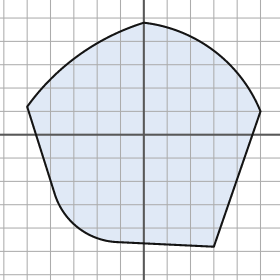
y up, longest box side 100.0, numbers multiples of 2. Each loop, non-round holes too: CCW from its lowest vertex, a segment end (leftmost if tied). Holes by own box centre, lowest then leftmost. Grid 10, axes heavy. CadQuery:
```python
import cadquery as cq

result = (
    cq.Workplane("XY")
    .moveTo(30.0, -48.0)
    .lineTo(50.0, 10.0)
    .threePointArc((30.0, 36.0), (0.0, 48.0))
    .threePointArc((-28.0, 34.0), (-50.0, 12.0))
    .lineTo(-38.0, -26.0)
    .threePointArc((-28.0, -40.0), (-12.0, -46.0))
    .close()
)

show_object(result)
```